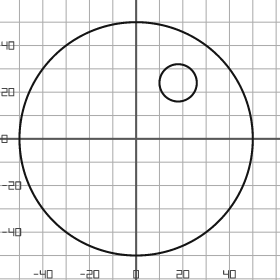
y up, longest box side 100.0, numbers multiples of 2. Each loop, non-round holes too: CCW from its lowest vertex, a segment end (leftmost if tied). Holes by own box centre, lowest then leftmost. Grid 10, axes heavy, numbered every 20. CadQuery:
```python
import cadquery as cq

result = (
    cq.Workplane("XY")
    .moveTo(0.0, 0.0)
    .circle(50.0)
    .moveTo(18.0, 24.0)
    .circle(8.0)
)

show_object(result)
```